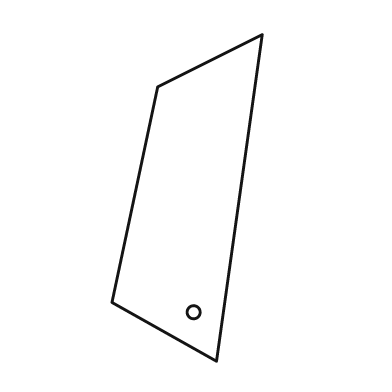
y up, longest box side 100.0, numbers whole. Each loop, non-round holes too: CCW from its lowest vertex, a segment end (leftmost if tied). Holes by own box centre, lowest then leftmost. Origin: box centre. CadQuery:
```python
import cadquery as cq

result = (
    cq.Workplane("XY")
    .moveTo(9.0, -50.0)
    .lineTo(23.0, 50.0)
    .lineTo(-9.0, 34.0)
    .lineTo(-23.0, -32.0)
    .close()
    .moveTo(2.0, -35.0)
    .circle(2.0)
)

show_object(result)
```